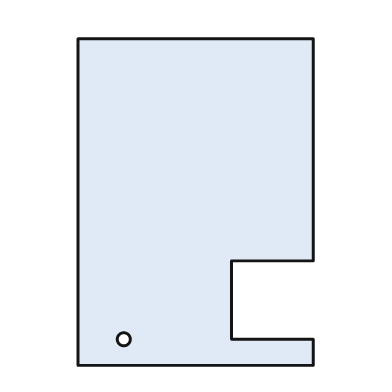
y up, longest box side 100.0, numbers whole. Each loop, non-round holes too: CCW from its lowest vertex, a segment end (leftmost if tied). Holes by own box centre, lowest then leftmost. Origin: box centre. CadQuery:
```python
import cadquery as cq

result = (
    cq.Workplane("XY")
    .moveTo(-36.0, -50.0)
    .lineTo(36.0, -50.0)
    .lineTo(36.0, -42.0)
    .lineTo(11.0, -42.0)
    .lineTo(11.0, -18.0)
    .lineTo(36.0, -18.0)
    .lineTo(36.0, 50.0)
    .lineTo(-36.0, 50.0)
    .close()
    .moveTo(-22.0, -42.0)
    .circle(2.0)
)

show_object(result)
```